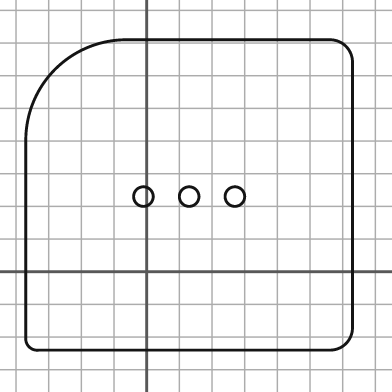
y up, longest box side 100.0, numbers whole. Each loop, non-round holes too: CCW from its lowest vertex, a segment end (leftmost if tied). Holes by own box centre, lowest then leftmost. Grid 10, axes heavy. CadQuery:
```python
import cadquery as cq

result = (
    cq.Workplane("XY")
    .moveTo(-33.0, -24.0)
    .lineTo(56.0, -24.0)
    .threePointArc((61.0, -22.0), (63.0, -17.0))
    .lineTo(63.0, 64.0)
    .threePointArc((61.0, 69.0), (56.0, 71.0))
    .lineTo(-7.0, 71.0)
    .threePointArc((-28.0, 62.0), (-37.0, 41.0))
    .lineTo(-37.0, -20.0)
    .threePointArc((-36.0, -23.0), (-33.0, -24.0))
    .close()
    .moveTo(-1.0, 23.0)
    .circle(3.0)
    .moveTo(13.0, 23.0)
    .circle(3.0)
    .moveTo(27.0, 23.0)
    .circle(3.0)
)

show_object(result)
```